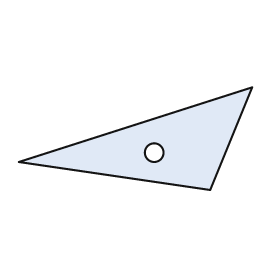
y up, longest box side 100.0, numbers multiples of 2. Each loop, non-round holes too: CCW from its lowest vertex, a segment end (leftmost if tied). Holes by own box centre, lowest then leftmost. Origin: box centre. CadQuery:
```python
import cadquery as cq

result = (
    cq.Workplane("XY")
    .moveTo(32.0, -22.0)
    .lineTo(50.0, 22.0)
    .lineTo(-50.0, -10.0)
    .close()
    .moveTo(8.0, -6.0)
    .circle(4.0)
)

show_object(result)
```